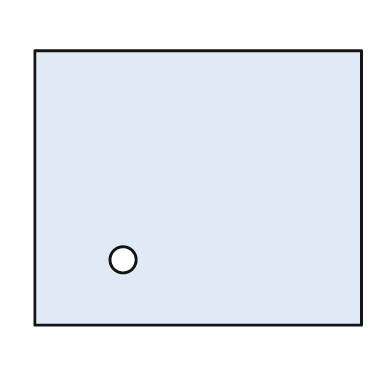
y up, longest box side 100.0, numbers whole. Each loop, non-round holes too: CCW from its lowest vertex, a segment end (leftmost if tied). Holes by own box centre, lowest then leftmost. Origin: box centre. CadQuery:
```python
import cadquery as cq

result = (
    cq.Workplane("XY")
    .moveTo(-50.0, -42.0)
    .lineTo(50.0, -42.0)
    .lineTo(50.0, 42.0)
    .lineTo(-50.0, 42.0)
    .close()
    .moveTo(-23.0, -22.0)
    .circle(4.0)
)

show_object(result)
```